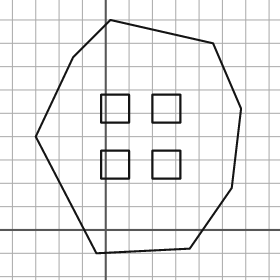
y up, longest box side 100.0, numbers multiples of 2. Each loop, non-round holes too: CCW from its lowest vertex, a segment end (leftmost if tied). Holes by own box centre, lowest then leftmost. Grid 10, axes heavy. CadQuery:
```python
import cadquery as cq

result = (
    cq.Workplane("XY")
    .moveTo(-4.0, -10.0)
    .lineTo(36.0, -8.0)
    .lineTo(54.0, 18.0)
    .lineTo(58.0, 52.0)
    .lineTo(46.0, 80.0)
    .lineTo(2.0, 90.0)
    .lineTo(-14.0, 74.0)
    .lineTo(-30.0, 40.0)
    .close()
    .moveTo(-2.0, 22.0)
    .lineTo(10.0, 22.0)
    .lineTo(10.0, 34.0)
    .lineTo(-2.0, 34.0)
    .close()
    .moveTo(20.0, 22.0)
    .lineTo(32.0, 22.0)
    .lineTo(32.0, 34.0)
    .lineTo(20.0, 34.0)
    .close()
    .moveTo(-2.0, 46.0)
    .lineTo(10.0, 46.0)
    .lineTo(10.0, 58.0)
    .lineTo(-2.0, 58.0)
    .close()
    .moveTo(20.0, 46.0)
    .lineTo(32.0, 46.0)
    .lineTo(32.0, 58.0)
    .lineTo(20.0, 58.0)
    .close()
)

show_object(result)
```